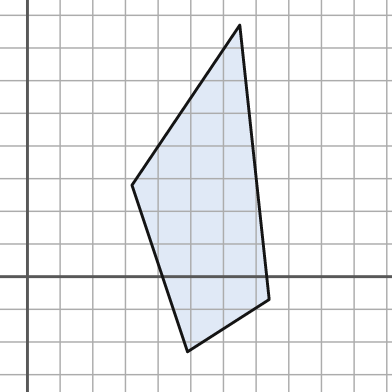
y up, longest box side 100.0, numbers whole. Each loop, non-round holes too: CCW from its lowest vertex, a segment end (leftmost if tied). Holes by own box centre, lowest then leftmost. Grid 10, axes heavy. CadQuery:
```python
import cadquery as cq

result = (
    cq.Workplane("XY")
    .moveTo(49.0, -23.0)
    .lineTo(74.0, -7.0)
    .lineTo(65.0, 77.0)
    .lineTo(32.0, 28.0)
    .close()
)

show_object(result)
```